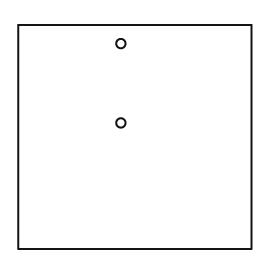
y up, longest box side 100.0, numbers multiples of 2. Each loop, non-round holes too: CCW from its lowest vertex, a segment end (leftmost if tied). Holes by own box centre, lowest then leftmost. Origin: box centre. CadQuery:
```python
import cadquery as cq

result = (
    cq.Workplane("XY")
    .moveTo(-50.0, -48.0)
    .lineTo(50.0, -48.0)
    .lineTo(50.0, 48.0)
    .lineTo(-50.0, 48.0)
    .close()
    .moveTo(-6.0, 6.0)
    .circle(2.0)
    .moveTo(-6.0, 40.0)
    .circle(2.0)
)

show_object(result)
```